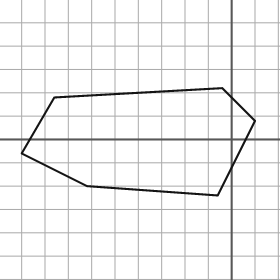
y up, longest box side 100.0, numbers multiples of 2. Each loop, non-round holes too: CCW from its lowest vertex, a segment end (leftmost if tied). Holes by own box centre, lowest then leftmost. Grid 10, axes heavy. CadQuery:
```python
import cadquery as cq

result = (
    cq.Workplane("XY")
    .moveTo(-6.0, -24.0)
    .lineTo(10.0, 8.0)
    .lineTo(-4.0, 22.0)
    .lineTo(-76.0, 18.0)
    .lineTo(-90.0, -6.0)
    .lineTo(-62.0, -20.0)
    .close()
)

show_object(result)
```